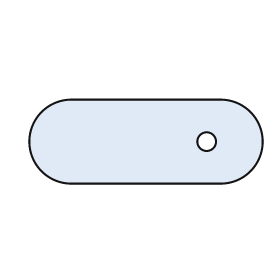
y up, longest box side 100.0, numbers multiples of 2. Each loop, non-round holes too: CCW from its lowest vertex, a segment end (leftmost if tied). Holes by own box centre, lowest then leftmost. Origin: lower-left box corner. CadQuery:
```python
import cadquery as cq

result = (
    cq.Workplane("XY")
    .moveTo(18.0, 0.0)
    .lineTo(82.0, 0.0)
    .threePointArc((100.0, 18.0), (82.0, 36.0))
    .lineTo(18.0, 36.0)
    .threePointArc((0.0, 18.0), (18.0, 0.0))
    .close()
    .moveTo(76.0, 18.0)
    .circle(4.0)
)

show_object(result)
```